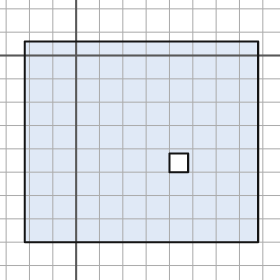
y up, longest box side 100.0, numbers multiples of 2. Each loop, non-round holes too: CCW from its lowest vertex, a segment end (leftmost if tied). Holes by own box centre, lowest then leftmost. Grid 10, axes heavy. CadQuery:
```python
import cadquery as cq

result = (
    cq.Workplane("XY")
    .moveTo(-22.0, -80.0)
    .lineTo(78.0, -80.0)
    .lineTo(78.0, 6.0)
    .lineTo(-22.0, 6.0)
    .close()
    .moveTo(40.0, -50.0)
    .lineTo(48.0, -50.0)
    .lineTo(48.0, -42.0)
    .lineTo(40.0, -42.0)
    .close()
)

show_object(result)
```